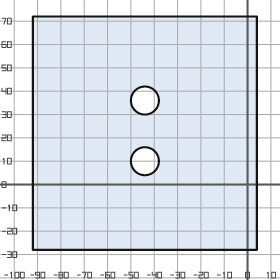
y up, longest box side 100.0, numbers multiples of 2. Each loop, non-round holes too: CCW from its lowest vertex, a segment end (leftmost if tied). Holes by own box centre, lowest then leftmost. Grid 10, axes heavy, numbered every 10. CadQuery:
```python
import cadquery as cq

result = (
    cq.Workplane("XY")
    .moveTo(-92.0, -28.0)
    .lineTo(4.0, -28.0)
    .lineTo(4.0, 72.0)
    .lineTo(-92.0, 72.0)
    .close()
    .moveTo(-44.0, 10.0)
    .circle(6.0)
    .moveTo(-44.0, 36.0)
    .circle(6.0)
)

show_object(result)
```